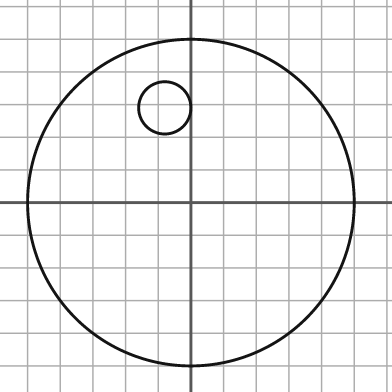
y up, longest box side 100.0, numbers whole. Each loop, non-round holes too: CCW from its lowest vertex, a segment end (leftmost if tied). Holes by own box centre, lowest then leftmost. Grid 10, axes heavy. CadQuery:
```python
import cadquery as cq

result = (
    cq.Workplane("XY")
    .moveTo(0.0, 0.0)
    .circle(50.0)
    .moveTo(-8.0, 29.0)
    .circle(8.0)
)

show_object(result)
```